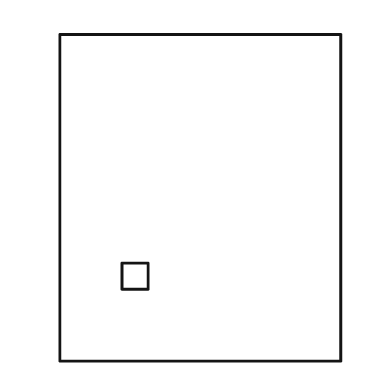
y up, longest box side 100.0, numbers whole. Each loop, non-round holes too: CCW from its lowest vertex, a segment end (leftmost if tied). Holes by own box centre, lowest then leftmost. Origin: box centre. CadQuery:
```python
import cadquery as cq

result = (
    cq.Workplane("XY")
    .moveTo(-43.0, -50.0)
    .lineTo(43.0, -50.0)
    .lineTo(43.0, 50.0)
    .lineTo(-43.0, 50.0)
    .close()
    .moveTo(-24.0, -28.0)
    .lineTo(-16.0, -28.0)
    .lineTo(-16.0, -20.0)
    .lineTo(-24.0, -20.0)
    .close()
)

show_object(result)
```